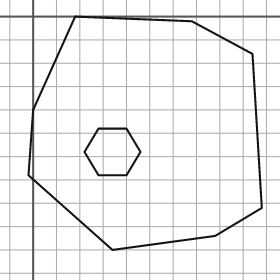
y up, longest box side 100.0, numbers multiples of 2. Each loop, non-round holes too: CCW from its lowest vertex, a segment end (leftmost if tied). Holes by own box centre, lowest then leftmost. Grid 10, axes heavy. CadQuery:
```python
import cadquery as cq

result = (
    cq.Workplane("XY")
    .moveTo(34.0, -100.0)
    .lineTo(78.0, -94.0)
    .lineTo(98.0, -82.0)
    .lineTo(94.0, -16.0)
    .lineTo(68.0, -2.0)
    .lineTo(18.0, 0.0)
    .lineTo(0.0, -40.0)
    .lineTo(-2.0, -68.0)
    .close()
    .moveTo(28.0, -68.0)
    .lineTo(40.0, -68.0)
    .lineTo(46.0, -58.0)
    .lineTo(40.0, -48.0)
    .lineTo(28.0, -48.0)
    .lineTo(22.0, -58.0)
    .close()
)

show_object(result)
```